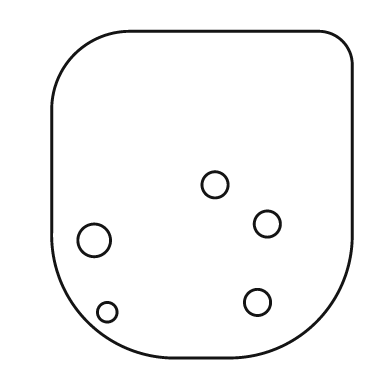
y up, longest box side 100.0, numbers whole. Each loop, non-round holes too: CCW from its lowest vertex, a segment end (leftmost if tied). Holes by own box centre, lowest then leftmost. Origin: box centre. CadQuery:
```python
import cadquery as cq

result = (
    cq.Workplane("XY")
    .moveTo(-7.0, -50.0)
    .lineTo(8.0, -50.0)
    .threePointArc((35.0, -39.0), (46.0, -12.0))
    .lineTo(46.0, 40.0)
    .threePointArc((43.0, 47.0), (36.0, 50.0))
    .lineTo(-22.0, 50.0)
    .threePointArc((-39.0, 43.0), (-46.0, 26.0))
    .lineTo(-46.0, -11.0)
    .threePointArc((-35.0, -39.0), (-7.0, -50.0))
    .close()
    .moveTo(-29.0, -36.0)
    .circle(3.0)
    .moveTo(17.0, -33.0)
    .circle(4.0)
    .moveTo(-33.0, -14.0)
    .circle(5.0)
    .moveTo(20.0, -9.0)
    .circle(4.0)
    .moveTo(4.0, 3.0)
    .circle(4.0)
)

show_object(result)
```